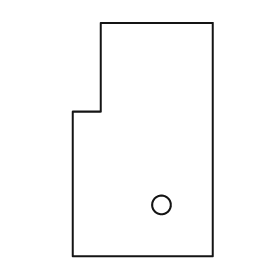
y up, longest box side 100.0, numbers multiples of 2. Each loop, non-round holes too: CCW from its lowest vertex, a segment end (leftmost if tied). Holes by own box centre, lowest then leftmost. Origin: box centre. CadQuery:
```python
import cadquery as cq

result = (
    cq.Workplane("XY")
    .moveTo(-30.0, -50.0)
    .lineTo(30.0, -50.0)
    .lineTo(30.0, 50.0)
    .lineTo(-18.0, 50.0)
    .lineTo(-18.0, 12.0)
    .lineTo(-30.0, 12.0)
    .close()
    .moveTo(8.0, -28.0)
    .circle(4.0)
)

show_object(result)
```